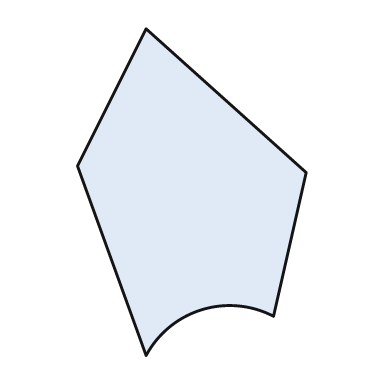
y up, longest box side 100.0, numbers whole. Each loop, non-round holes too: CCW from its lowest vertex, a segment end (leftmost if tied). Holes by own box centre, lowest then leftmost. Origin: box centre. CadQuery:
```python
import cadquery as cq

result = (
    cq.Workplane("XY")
    .moveTo(-14.0, -50.0)
    .threePointArc((3.0, -36.0), (25.0, -38.0))
    .lineTo(35.0, 6.0)
    .lineTo(-14.0, 50.0)
    .lineTo(-35.0, 8.0)
    .close()
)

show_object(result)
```